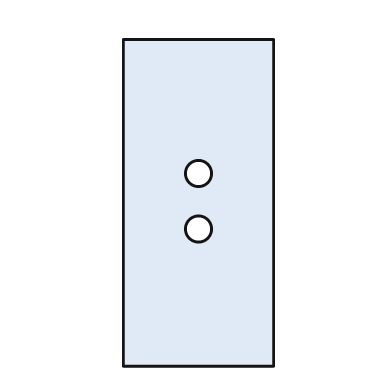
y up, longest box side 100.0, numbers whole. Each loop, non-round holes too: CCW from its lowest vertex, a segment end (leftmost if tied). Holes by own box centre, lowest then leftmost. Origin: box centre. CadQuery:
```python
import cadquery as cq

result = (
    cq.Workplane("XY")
    .moveTo(-23.0, -50.0)
    .lineTo(23.0, -50.0)
    .lineTo(23.0, 50.0)
    .lineTo(-23.0, 50.0)
    .close()
    .moveTo(0.0, -8.0)
    .circle(4.0)
    .moveTo(0.0, 9.0)
    .circle(4.0)
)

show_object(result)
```